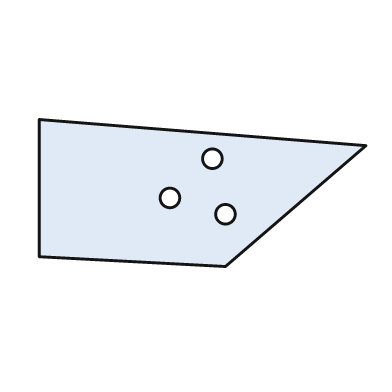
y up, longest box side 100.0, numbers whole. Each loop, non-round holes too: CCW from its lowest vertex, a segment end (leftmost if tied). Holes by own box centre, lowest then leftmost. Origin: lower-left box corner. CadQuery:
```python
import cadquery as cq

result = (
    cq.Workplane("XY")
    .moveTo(57.0, 0.0)
    .lineTo(100.0, 37.0)
    .lineTo(0.0, 45.0)
    .lineTo(0.0, 3.0)
    .close()
    .moveTo(57.0, 16.0)
    .circle(3.0)
    .moveTo(40.0, 21.0)
    .circle(3.0)
    .moveTo(53.0, 33.0)
    .circle(3.0)
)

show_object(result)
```